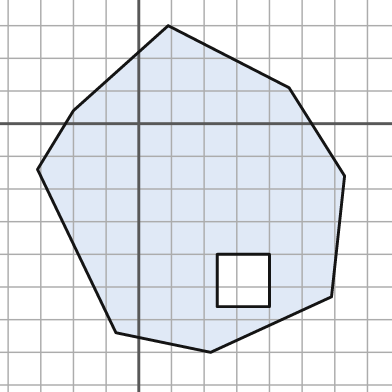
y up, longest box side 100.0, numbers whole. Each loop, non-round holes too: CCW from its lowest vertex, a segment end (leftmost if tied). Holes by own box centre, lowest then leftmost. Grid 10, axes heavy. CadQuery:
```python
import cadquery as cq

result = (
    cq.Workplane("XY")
    .moveTo(22.0, -70.0)
    .lineTo(59.0, -53.0)
    .lineTo(63.0, -16.0)
    .lineTo(46.0, 11.0)
    .lineTo(9.0, 30.0)
    .lineTo(-20.0, 4.0)
    .lineTo(-31.0, -14.0)
    .lineTo(-7.0, -64.0)
    .close()
    .moveTo(24.0, -56.0)
    .lineTo(40.0, -56.0)
    .lineTo(40.0, -40.0)
    .lineTo(24.0, -40.0)
    .close()
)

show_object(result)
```